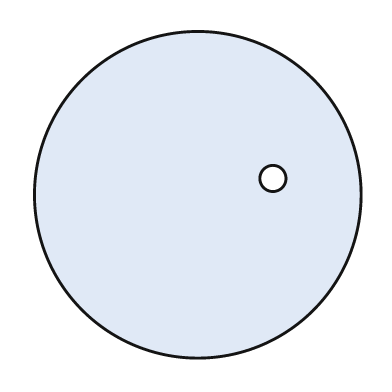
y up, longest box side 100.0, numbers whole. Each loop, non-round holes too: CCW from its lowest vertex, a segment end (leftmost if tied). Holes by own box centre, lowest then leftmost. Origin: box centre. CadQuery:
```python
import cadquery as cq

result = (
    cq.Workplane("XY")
    .moveTo(0.0, 0.0)
    .circle(50.0)
    .moveTo(23.0, 5.0)
    .circle(4.0)
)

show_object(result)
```